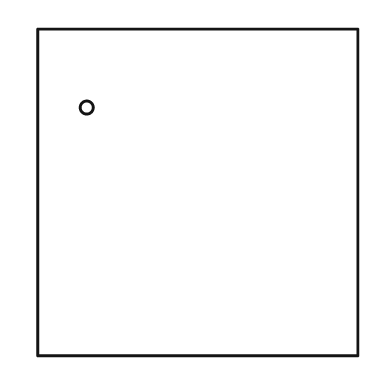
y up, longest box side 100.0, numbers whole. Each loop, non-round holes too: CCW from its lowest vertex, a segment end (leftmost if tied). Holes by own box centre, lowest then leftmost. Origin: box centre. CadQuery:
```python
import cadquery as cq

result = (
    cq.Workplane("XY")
    .moveTo(-49.0, -50.0)
    .lineTo(49.0, -50.0)
    .lineTo(49.0, 50.0)
    .lineTo(-49.0, 50.0)
    .close()
    .moveTo(-34.0, 26.0)
    .circle(2.0)
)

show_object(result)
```